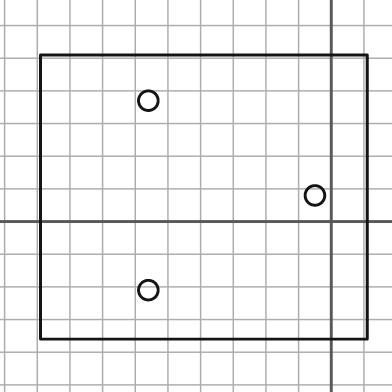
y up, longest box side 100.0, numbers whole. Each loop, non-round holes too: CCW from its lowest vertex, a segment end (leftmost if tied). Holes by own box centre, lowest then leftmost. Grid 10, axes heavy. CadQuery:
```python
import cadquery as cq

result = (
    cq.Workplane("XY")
    .moveTo(-89.0, -36.0)
    .lineTo(11.0, -36.0)
    .lineTo(11.0, 51.0)
    .lineTo(-89.0, 51.0)
    .close()
    .moveTo(-56.0, -21.0)
    .circle(3.0)
    .moveTo(-5.0, 8.0)
    .circle(3.0)
    .moveTo(-56.0, 37.0)
    .circle(3.0)
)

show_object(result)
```